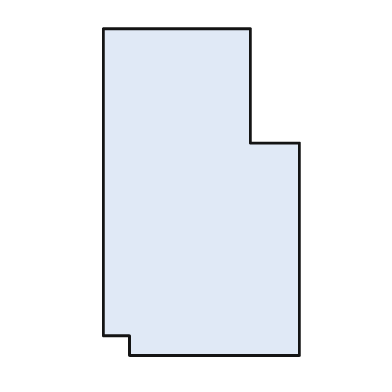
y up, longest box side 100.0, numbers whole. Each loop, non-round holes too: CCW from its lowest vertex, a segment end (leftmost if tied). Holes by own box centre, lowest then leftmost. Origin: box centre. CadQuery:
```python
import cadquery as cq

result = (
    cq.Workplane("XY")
    .moveTo(-22.0, -50.0)
    .lineTo(30.0, -50.0)
    .lineTo(30.0, 15.0)
    .lineTo(15.0, 15.0)
    .lineTo(15.0, 50.0)
    .lineTo(-30.0, 50.0)
    .lineTo(-30.0, -44.0)
    .lineTo(-22.0, -44.0)
    .close()
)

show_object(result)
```